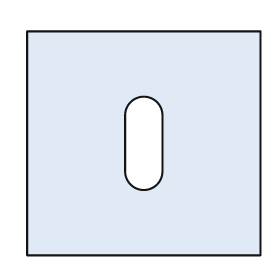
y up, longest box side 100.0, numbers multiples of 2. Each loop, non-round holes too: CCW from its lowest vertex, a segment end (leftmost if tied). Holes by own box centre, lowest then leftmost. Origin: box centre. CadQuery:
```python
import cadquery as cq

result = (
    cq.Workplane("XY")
    .moveTo(-50.0, -48.0)
    .lineTo(50.0, -48.0)
    .lineTo(50.0, 48.0)
    .lineTo(-50.0, 48.0)
    .close()
    .moveTo(-8.0, -12.0)
    .threePointArc((0.0, -20.0), (8.0, -12.0))
    .lineTo(8.0, 12.0)
    .threePointArc((0.0, 20.0), (-8.0, 12.0))
    .close()
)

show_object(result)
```